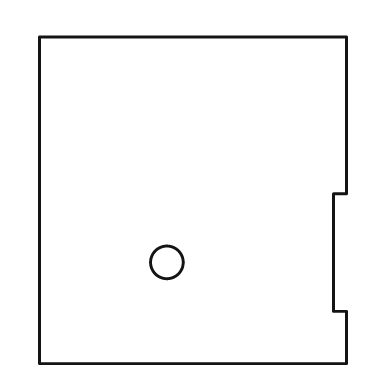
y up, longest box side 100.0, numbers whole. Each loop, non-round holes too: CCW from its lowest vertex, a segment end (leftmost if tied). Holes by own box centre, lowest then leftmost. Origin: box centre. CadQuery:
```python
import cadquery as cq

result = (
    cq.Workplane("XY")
    .moveTo(-47.0, -50.0)
    .lineTo(47.0, -50.0)
    .lineTo(47.0, -34.0)
    .lineTo(43.0, -34.0)
    .lineTo(43.0, 2.0)
    .lineTo(47.0, 2.0)
    .lineTo(47.0, 50.0)
    .lineTo(-47.0, 50.0)
    .close()
    .moveTo(-8.0, -19.0)
    .circle(5.0)
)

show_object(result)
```